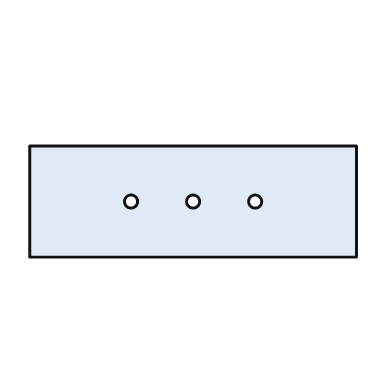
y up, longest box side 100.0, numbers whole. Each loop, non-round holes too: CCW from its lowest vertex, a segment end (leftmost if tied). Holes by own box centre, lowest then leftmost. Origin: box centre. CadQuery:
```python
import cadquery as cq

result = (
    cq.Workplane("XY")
    .moveTo(-50.0, -17.0)
    .lineTo(50.0, -17.0)
    .lineTo(50.0, 17.0)
    .lineTo(-50.0, 17.0)
    .close()
    .moveTo(-19.0, 0.0)
    .circle(2.0)
    .moveTo(0.0, 0.0)
    .circle(2.0)
    .moveTo(19.0, 0.0)
    .circle(2.0)
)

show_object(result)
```